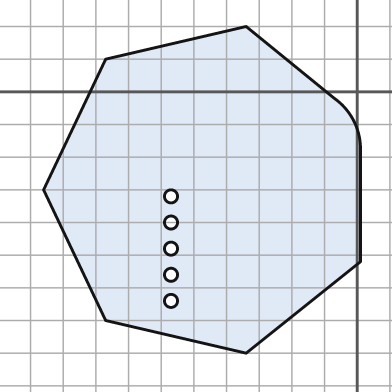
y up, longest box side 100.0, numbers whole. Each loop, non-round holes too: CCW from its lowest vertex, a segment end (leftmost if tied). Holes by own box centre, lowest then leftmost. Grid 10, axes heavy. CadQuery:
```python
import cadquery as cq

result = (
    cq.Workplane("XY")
    .moveTo(-34.0, -80.0)
    .lineTo(1.0, -52.0)
    .lineTo(1.0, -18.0)
    .threePointArc((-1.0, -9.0), (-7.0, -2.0))
    .lineTo(-34.0, 20.0)
    .lineTo(-77.0, 10.0)
    .lineTo(-96.0, -30.0)
    .lineTo(-77.0, -70.0)
    .close()
    .moveTo(-57.0, -64.0)
    .circle(2.0)
    .moveTo(-57.0, -56.0)
    .circle(2.0)
    .moveTo(-57.0, -48.0)
    .circle(2.0)
    .moveTo(-57.0, -40.0)
    .circle(2.0)
    .moveTo(-57.0, -32.0)
    .circle(2.0)
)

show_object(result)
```